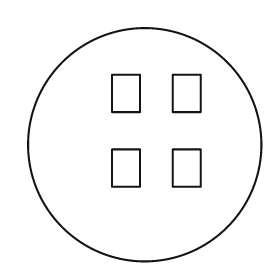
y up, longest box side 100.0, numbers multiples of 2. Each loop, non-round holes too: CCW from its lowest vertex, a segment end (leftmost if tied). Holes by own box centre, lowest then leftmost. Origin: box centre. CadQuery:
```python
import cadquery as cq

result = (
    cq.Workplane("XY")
    .moveTo(0.0, 0.0)
    .circle(50.0)
    .moveTo(-14.0, -18.0)
    .lineTo(-2.0, -18.0)
    .lineTo(-2.0, -2.0)
    .lineTo(-14.0, -2.0)
    .close()
    .moveTo(12.0, -18.0)
    .lineTo(24.0, -18.0)
    .lineTo(24.0, -2.0)
    .lineTo(12.0, -2.0)
    .close()
    .moveTo(-14.0, 14.0)
    .lineTo(-2.0, 14.0)
    .lineTo(-2.0, 30.0)
    .lineTo(-14.0, 30.0)
    .close()
    .moveTo(12.0, 14.0)
    .lineTo(24.0, 14.0)
    .lineTo(24.0, 30.0)
    .lineTo(12.0, 30.0)
    .close()
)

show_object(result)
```